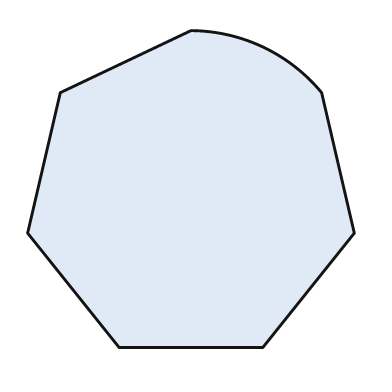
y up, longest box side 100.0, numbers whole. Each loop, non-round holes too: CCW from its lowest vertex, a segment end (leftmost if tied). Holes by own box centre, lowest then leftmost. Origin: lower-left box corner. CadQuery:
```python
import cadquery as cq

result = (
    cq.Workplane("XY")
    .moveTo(28.0, 0.0)
    .lineTo(72.0, 0.0)
    .lineTo(100.0, 35.0)
    .lineTo(90.0, 78.0)
    .threePointArc((72.0, 92.0), (50.0, 97.0))
    .lineTo(10.0, 78.0)
    .lineTo(0.0, 35.0)
    .close()
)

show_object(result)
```